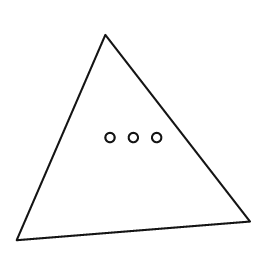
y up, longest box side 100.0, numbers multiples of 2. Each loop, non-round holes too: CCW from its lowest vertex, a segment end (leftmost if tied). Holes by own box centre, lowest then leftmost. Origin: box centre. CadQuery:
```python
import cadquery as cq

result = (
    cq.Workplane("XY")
    .moveTo(-50.0, -44.0)
    .lineTo(50.0, -36.0)
    .lineTo(-12.0, 44.0)
    .close()
    .moveTo(-10.0, 0.0)
    .circle(2.0)
    .moveTo(0.0, 0.0)
    .circle(2.0)
    .moveTo(10.0, 0.0)
    .circle(2.0)
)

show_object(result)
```